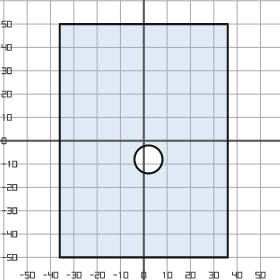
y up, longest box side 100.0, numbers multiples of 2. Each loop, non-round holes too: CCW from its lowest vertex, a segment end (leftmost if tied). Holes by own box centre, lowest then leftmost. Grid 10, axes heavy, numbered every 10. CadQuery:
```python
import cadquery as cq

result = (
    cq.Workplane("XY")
    .moveTo(-36.0, -50.0)
    .lineTo(36.0, -50.0)
    .lineTo(36.0, 50.0)
    .lineTo(-36.0, 50.0)
    .close()
    .moveTo(2.0, -8.0)
    .circle(6.0)
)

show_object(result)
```